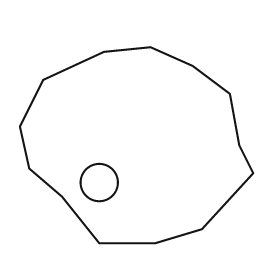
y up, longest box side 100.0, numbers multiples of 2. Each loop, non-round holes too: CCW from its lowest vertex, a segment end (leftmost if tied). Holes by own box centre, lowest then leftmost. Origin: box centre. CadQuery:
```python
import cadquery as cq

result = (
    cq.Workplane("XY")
    .moveTo(-16.0, -42.0)
    .lineTo(8.0, -42.0)
    .lineTo(28.0, -36.0)
    .lineTo(50.0, -12.0)
    .lineTo(44.0, 0.0)
    .lineTo(40.0, 22.0)
    .lineTo(24.0, 34.0)
    .lineTo(6.0, 42.0)
    .lineTo(-14.0, 40.0)
    .lineTo(-40.0, 28.0)
    .lineTo(-50.0, 8.0)
    .lineTo(-46.0, -10.0)
    .lineTo(-32.0, -22.0)
    .close()
    .moveTo(-16.0, -16.0)
    .circle(8.0)
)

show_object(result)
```